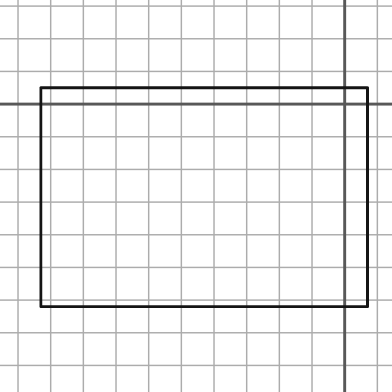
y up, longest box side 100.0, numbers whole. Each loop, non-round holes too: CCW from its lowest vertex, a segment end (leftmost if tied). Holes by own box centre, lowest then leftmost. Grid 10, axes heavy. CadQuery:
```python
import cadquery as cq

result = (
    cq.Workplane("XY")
    .moveTo(-93.0, -62.0)
    .lineTo(7.0, -62.0)
    .lineTo(7.0, 5.0)
    .lineTo(-93.0, 5.0)
    .close()
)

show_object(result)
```